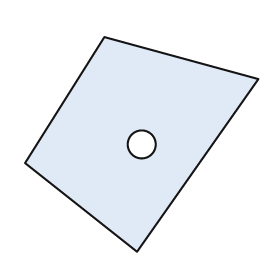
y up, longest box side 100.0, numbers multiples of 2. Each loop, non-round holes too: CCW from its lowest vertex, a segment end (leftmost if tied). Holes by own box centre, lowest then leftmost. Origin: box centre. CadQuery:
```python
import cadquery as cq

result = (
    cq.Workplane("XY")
    .moveTo(-2.0, -46.0)
    .lineTo(50.0, 28.0)
    .lineTo(-16.0, 46.0)
    .lineTo(-50.0, -8.0)
    .close()
    .moveTo(0.0, 0.0)
    .circle(6.0)
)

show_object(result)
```